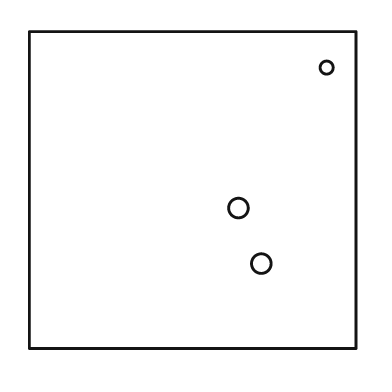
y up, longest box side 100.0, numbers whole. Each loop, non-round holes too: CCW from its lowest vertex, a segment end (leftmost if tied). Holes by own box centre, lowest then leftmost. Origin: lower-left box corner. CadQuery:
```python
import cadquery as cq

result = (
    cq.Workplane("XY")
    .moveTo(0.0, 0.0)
    .lineTo(100.0, 0.0)
    .lineTo(100.0, 97.0)
    .lineTo(0.0, 97.0)
    .close()
    .moveTo(71.0, 26.0)
    .circle(3.0)
    .moveTo(64.0, 43.0)
    .circle(3.0)
    .moveTo(91.0, 86.0)
    .circle(2.0)
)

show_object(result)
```